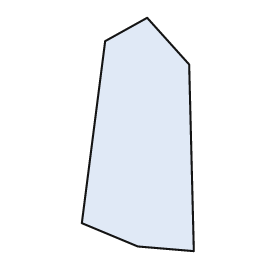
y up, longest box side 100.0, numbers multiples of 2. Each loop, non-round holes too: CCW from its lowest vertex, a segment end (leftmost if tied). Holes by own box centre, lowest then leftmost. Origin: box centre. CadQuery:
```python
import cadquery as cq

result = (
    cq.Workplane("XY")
    .moveTo(24.0, -50.0)
    .lineTo(22.0, 30.0)
    .lineTo(4.0, 50.0)
    .lineTo(-14.0, 40.0)
    .lineTo(-24.0, -38.0)
    .lineTo(0.0, -48.0)
    .close()
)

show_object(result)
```